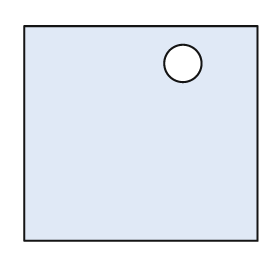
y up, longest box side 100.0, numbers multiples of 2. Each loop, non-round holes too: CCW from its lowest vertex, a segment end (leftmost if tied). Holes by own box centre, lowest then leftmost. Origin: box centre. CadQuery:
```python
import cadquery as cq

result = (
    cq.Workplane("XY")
    .moveTo(-50.0, -46.0)
    .lineTo(50.0, -46.0)
    .lineTo(50.0, 46.0)
    .lineTo(-50.0, 46.0)
    .close()
    .moveTo(18.0, 30.0)
    .circle(8.0)
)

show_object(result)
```